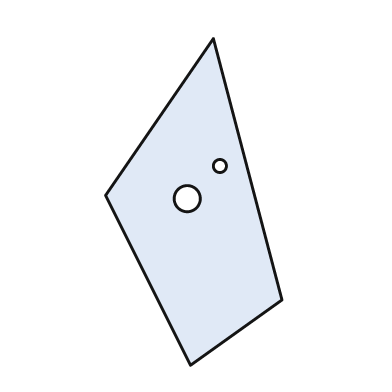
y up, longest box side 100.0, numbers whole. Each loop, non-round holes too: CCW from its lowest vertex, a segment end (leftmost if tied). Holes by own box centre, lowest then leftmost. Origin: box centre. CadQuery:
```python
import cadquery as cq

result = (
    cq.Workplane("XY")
    .moveTo(-1.0, -50.0)
    .lineTo(27.0, -30.0)
    .lineTo(6.0, 50.0)
    .lineTo(-27.0, 2.0)
    .close()
    .moveTo(-2.0, 1.0)
    .circle(4.0)
    .moveTo(8.0, 11.0)
    .circle(2.0)
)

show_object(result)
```